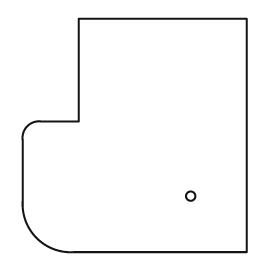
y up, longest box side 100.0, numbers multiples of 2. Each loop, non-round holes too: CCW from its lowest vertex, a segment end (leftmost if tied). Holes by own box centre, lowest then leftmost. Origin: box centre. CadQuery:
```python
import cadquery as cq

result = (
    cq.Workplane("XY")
    .moveTo(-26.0, -50.0)
    .lineTo(48.0, -50.0)
    .lineTo(48.0, 50.0)
    .lineTo(-24.0, 50.0)
    .lineTo(-24.0, 6.0)
    .lineTo(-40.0, 6.0)
    .threePointArc((-46.0, 4.0), (-48.0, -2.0))
    .lineTo(-48.0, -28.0)
    .threePointArc((-42.0, -44.0), (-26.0, -50.0))
    .close()
    .moveTo(24.0, -26.0)
    .circle(2.0)
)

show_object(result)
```